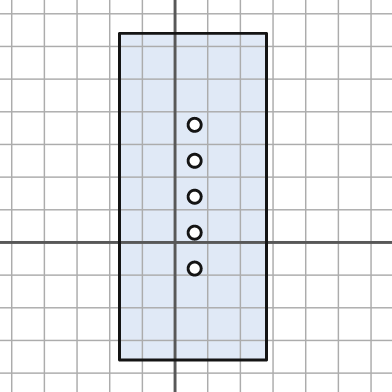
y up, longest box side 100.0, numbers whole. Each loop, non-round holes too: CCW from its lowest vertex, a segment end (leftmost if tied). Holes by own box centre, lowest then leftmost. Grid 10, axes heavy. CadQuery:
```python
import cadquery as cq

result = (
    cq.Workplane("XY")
    .moveTo(-17.0, -36.0)
    .lineTo(28.0, -36.0)
    .lineTo(28.0, 64.0)
    .lineTo(-17.0, 64.0)
    .close()
    .moveTo(6.0, -8.0)
    .circle(2.0)
    .moveTo(6.0, 3.0)
    .circle(2.0)
    .moveTo(6.0, 14.0)
    .circle(2.0)
    .moveTo(6.0, 25.0)
    .circle(2.0)
    .moveTo(6.0, 36.0)
    .circle(2.0)
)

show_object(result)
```